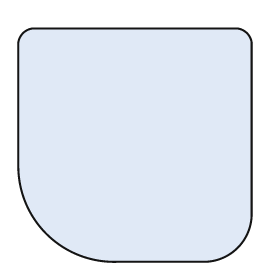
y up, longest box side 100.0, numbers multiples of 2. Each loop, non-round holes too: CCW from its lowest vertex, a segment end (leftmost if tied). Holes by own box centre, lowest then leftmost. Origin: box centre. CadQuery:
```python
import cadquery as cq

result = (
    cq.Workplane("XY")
    .moveTo(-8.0, -50.0)
    .lineTo(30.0, -50.0)
    .threePointArc((44.0, -44.0), (50.0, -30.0))
    .lineTo(50.0, 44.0)
    .threePointArc((48.0, 48.0), (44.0, 50.0))
    .lineTo(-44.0, 50.0)
    .threePointArc((-48.0, 48.0), (-50.0, 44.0))
    .lineTo(-50.0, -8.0)
    .threePointArc((-38.0, -38.0), (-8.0, -50.0))
    .close()
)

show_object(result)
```